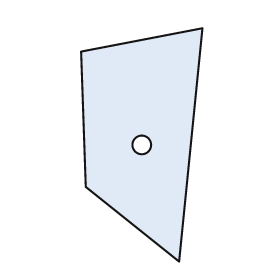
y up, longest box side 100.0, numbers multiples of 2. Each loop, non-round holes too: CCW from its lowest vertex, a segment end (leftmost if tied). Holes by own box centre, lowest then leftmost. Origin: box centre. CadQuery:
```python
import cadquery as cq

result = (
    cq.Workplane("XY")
    .moveTo(16.0, -50.0)
    .lineTo(26.0, 50.0)
    .lineTo(-26.0, 40.0)
    .lineTo(-24.0, -18.0)
    .close()
    .moveTo(0.0, 0.0)
    .circle(4.0)
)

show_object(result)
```